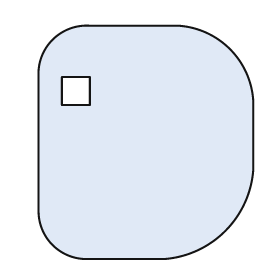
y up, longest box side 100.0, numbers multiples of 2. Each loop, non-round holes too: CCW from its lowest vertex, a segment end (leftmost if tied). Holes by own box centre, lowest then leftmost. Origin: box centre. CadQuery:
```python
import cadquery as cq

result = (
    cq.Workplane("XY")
    .moveTo(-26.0, -50.0)
    .lineTo(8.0, -50.0)
    .threePointArc((34.0, -38.0), (46.0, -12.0))
    .lineTo(46.0, 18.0)
    .threePointArc((36.0, 40.0), (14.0, 50.0))
    .lineTo(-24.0, 50.0)
    .threePointArc((-40.0, 44.0), (-46.0, 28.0))
    .lineTo(-46.0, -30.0)
    .threePointArc((-40.0, -44.0), (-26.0, -50.0))
    .close()
    .moveTo(-36.0, 16.0)
    .lineTo(-24.0, 16.0)
    .lineTo(-24.0, 28.0)
    .lineTo(-36.0, 28.0)
    .close()
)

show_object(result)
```